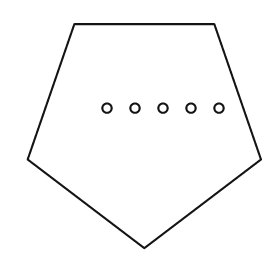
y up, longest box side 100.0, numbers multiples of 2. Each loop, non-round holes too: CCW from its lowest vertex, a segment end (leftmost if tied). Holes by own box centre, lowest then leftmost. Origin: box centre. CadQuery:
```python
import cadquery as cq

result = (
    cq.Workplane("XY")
    .moveTo(0.0, -48.0)
    .lineTo(50.0, -10.0)
    .lineTo(30.0, 48.0)
    .lineTo(-30.0, 48.0)
    .lineTo(-50.0, -10.0)
    .close()
    .moveTo(-16.0, 12.0)
    .circle(2.0)
    .moveTo(-4.0, 12.0)
    .circle(2.0)
    .moveTo(8.0, 12.0)
    .circle(2.0)
    .moveTo(20.0, 12.0)
    .circle(2.0)
    .moveTo(32.0, 12.0)
    .circle(2.0)
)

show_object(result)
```